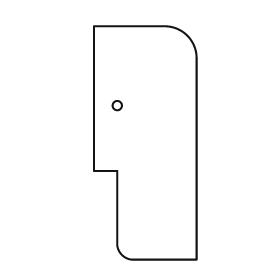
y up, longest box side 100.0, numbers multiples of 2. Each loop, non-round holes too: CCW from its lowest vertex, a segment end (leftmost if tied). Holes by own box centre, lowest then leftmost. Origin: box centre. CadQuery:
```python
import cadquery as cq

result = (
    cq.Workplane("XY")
    .moveTo(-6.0, -50.0)
    .lineTo(22.0, -50.0)
    .lineTo(22.0, 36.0)
    .threePointArc((18.0, 46.0), (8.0, 50.0))
    .lineTo(-22.0, 50.0)
    .lineTo(-22.0, -12.0)
    .lineTo(-12.0, -12.0)
    .lineTo(-12.0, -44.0)
    .threePointArc((-10.0, -48.0), (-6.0, -50.0))
    .close()
    .moveTo(-12.0, 16.0)
    .circle(2.0)
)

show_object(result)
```